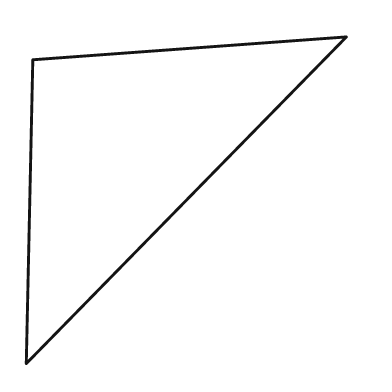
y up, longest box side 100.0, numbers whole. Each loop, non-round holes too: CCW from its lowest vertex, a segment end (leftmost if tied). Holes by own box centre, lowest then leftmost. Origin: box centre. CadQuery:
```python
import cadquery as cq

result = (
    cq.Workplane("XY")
    .moveTo(-49.0, -50.0)
    .lineTo(49.0, 50.0)
    .lineTo(-47.0, 43.0)
    .close()
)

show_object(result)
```